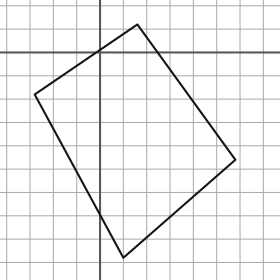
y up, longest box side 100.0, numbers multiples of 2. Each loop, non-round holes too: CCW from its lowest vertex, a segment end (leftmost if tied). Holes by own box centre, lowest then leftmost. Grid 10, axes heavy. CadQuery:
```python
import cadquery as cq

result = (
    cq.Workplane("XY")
    .moveTo(10.0, -88.0)
    .lineTo(58.0, -46.0)
    .lineTo(16.0, 12.0)
    .lineTo(-28.0, -18.0)
    .close()
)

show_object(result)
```